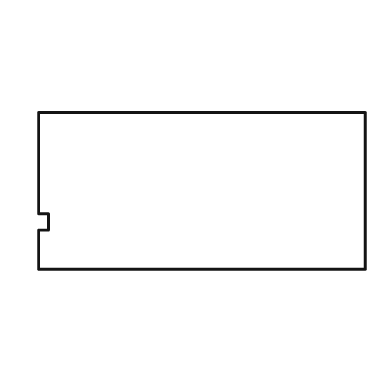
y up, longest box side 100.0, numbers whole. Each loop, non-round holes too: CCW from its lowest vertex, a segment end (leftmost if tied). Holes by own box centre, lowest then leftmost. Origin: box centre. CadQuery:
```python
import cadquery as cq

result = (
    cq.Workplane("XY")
    .moveTo(-50.0, -24.0)
    .lineTo(50.0, -24.0)
    .lineTo(50.0, 24.0)
    .lineTo(-50.0, 24.0)
    .lineTo(-50.0, -7.0)
    .lineTo(-47.0, -7.0)
    .lineTo(-47.0, -12.0)
    .lineTo(-50.0, -12.0)
    .close()
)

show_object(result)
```